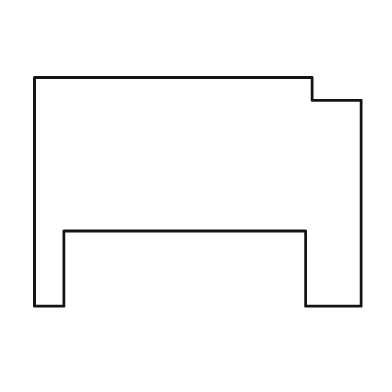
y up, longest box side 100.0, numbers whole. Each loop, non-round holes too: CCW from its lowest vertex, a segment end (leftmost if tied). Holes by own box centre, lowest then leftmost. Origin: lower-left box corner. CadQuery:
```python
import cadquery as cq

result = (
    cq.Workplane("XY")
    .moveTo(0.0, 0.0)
    .lineTo(9.0, 0.0)
    .lineTo(9.0, 23.0)
    .lineTo(83.0, 23.0)
    .lineTo(83.0, 0.0)
    .lineTo(100.0, 0.0)
    .lineTo(100.0, 63.0)
    .lineTo(85.0, 63.0)
    .lineTo(85.0, 70.0)
    .lineTo(0.0, 70.0)
    .close()
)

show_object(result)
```